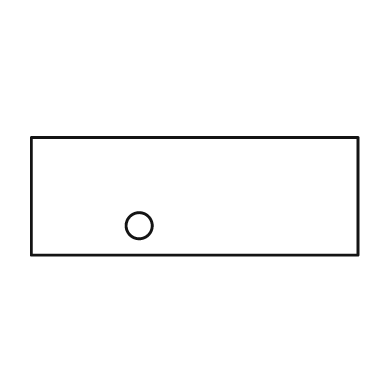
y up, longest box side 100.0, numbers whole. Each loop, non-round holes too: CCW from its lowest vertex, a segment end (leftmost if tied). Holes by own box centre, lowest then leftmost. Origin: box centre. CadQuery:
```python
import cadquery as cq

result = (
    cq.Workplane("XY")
    .moveTo(-50.0, -18.0)
    .lineTo(50.0, -18.0)
    .lineTo(50.0, 18.0)
    .lineTo(-50.0, 18.0)
    .close()
    .moveTo(-17.0, -9.0)
    .circle(4.0)
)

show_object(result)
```